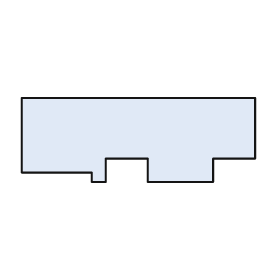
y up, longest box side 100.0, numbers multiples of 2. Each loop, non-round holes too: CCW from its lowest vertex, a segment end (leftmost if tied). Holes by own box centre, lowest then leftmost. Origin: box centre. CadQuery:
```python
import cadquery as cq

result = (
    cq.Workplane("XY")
    .moveTo(-20.0, -18.0)
    .lineTo(-14.0, -18.0)
    .lineTo(-14.0, -8.0)
    .lineTo(4.0, -8.0)
    .lineTo(4.0, -18.0)
    .lineTo(32.0, -18.0)
    .lineTo(32.0, -8.0)
    .lineTo(50.0, -8.0)
    .lineTo(50.0, 18.0)
    .lineTo(-50.0, 18.0)
    .lineTo(-50.0, -14.0)
    .lineTo(-20.0, -14.0)
    .close()
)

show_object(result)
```